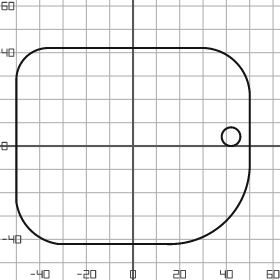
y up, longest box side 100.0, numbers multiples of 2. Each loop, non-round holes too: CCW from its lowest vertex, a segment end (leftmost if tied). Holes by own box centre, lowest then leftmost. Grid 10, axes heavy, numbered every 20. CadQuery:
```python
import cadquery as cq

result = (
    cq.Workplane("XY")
    .moveTo(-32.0, -42.0)
    .lineTo(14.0, -42.0)
    .threePointArc((40.0, -32.0), (50.0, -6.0))
    .lineTo(50.0, 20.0)
    .threePointArc((44.0, 36.0), (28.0, 42.0))
    .lineTo(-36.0, 42.0)
    .threePointArc((-46.0, 38.0), (-50.0, 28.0))
    .lineTo(-50.0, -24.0)
    .threePointArc((-44.0, -36.0), (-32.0, -42.0))
    .close()
    .moveTo(42.0, 4.0)
    .circle(4.0)
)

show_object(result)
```